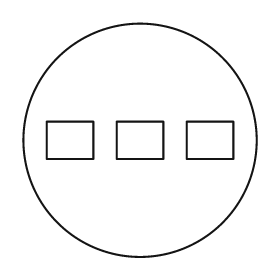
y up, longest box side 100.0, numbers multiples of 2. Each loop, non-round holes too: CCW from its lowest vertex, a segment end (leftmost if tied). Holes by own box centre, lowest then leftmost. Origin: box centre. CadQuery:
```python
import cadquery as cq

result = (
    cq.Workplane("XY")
    .moveTo(0.0, 0.0)
    .circle(50.0)
    .moveTo(-40.0, -8.0)
    .lineTo(-20.0, -8.0)
    .lineTo(-20.0, 8.0)
    .lineTo(-40.0, 8.0)
    .close()
    .moveTo(-10.0, -8.0)
    .lineTo(10.0, -8.0)
    .lineTo(10.0, 8.0)
    .lineTo(-10.0, 8.0)
    .close()
    .moveTo(20.0, -8.0)
    .lineTo(40.0, -8.0)
    .lineTo(40.0, 8.0)
    .lineTo(20.0, 8.0)
    .close()
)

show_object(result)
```